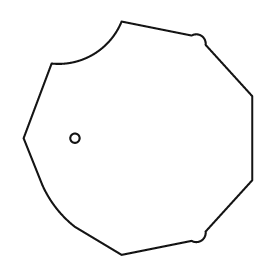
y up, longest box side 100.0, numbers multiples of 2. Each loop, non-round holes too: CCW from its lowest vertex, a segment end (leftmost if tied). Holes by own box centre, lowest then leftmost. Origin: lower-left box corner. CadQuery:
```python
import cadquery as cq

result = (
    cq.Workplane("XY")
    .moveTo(42.0, 0.0)
    .lineTo(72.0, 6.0)
    .threePointArc((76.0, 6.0), (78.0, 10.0))
    .lineTo(98.0, 32.0)
    .lineTo(98.0, 68.0)
    .lineTo(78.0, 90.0)
    .threePointArc((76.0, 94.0), (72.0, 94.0))
    .lineTo(42.0, 100.0)
    .threePointArc((30.0, 86.0), (12.0, 82.0))
    .lineTo(0.0, 50.0)
    .lineTo(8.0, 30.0)
    .threePointArc((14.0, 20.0), (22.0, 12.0))
    .close()
    .moveTo(22.0, 50.0)
    .circle(2.0)
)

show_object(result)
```